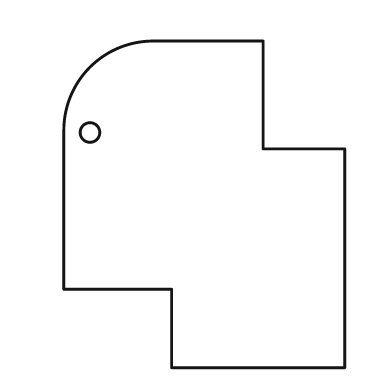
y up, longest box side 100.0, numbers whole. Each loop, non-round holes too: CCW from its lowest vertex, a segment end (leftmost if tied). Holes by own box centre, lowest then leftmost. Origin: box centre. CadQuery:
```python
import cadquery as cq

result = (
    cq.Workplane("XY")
    .moveTo(-10.0, -50.0)
    .lineTo(43.0, -50.0)
    .lineTo(43.0, 17.0)
    .lineTo(18.0, 17.0)
    .lineTo(18.0, 50.0)
    .lineTo(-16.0, 50.0)
    .threePointArc((-35.0, 42.0), (-43.0, 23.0))
    .lineTo(-43.0, -26.0)
    .lineTo(-10.0, -26.0)
    .close()
    .moveTo(-35.0, 22.0)
    .circle(3.0)
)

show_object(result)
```